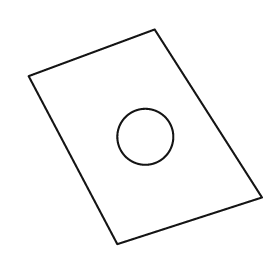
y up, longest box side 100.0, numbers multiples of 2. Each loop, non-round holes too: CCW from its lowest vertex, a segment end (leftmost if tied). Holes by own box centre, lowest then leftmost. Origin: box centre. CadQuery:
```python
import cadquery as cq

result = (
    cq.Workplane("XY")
    .moveTo(-12.0, -46.0)
    .lineTo(50.0, -26.0)
    .lineTo(4.0, 46.0)
    .lineTo(-50.0, 26.0)
    .close()
    .moveTo(0.0, 0.0)
    .circle(12.0)
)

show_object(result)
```